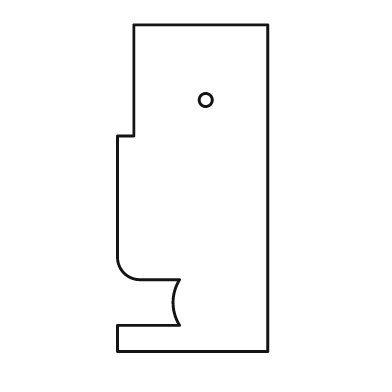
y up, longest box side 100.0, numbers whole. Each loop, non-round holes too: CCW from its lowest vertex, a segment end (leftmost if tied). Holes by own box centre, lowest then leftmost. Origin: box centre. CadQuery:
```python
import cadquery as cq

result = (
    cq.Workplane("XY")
    .moveTo(-23.0, -50.0)
    .lineTo(23.0, -50.0)
    .lineTo(23.0, 50.0)
    .lineTo(-18.0, 50.0)
    .lineTo(-18.0, 16.0)
    .lineTo(-23.0, 16.0)
    .lineTo(-23.0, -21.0)
    .threePointArc((-21.0, -26.0), (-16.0, -28.0))
    .lineTo(-4.0, -28.0)
    .threePointArc((-6.0, -35.0), (-4.0, -42.0))
    .lineTo(-23.0, -42.0)
    .close()
    .moveTo(4.0, 27.0)
    .circle(2.0)
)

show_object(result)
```